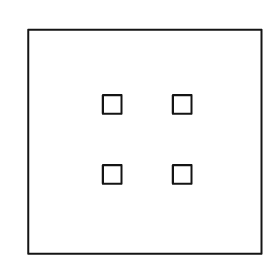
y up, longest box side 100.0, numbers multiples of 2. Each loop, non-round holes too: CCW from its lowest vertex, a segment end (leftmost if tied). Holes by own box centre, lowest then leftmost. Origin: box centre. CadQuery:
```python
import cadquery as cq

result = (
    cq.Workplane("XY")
    .moveTo(-50.0, -48.0)
    .lineTo(50.0, -48.0)
    .lineTo(50.0, 48.0)
    .lineTo(-50.0, 48.0)
    .close()
    .moveTo(-18.0, -18.0)
    .lineTo(-10.0, -18.0)
    .lineTo(-10.0, -10.0)
    .lineTo(-18.0, -10.0)
    .close()
    .moveTo(12.0, -18.0)
    .lineTo(20.0, -18.0)
    .lineTo(20.0, -10.0)
    .lineTo(12.0, -10.0)
    .close()
    .moveTo(-18.0, 12.0)
    .lineTo(-10.0, 12.0)
    .lineTo(-10.0, 20.0)
    .lineTo(-18.0, 20.0)
    .close()
    .moveTo(12.0, 12.0)
    .lineTo(20.0, 12.0)
    .lineTo(20.0, 20.0)
    .lineTo(12.0, 20.0)
    .close()
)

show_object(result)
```